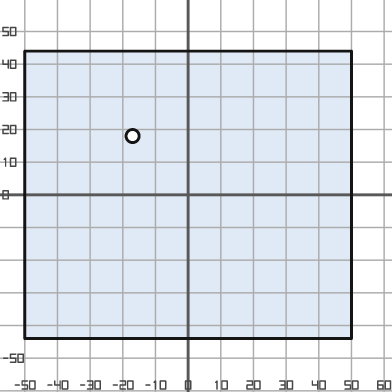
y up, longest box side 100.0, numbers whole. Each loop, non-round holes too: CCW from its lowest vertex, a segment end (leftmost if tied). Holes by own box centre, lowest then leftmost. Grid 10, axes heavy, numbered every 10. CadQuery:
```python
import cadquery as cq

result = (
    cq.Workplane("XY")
    .moveTo(-50.0, -44.0)
    .lineTo(50.0, -44.0)
    .lineTo(50.0, 44.0)
    .lineTo(-50.0, 44.0)
    .close()
    .moveTo(-17.0, 18.0)
    .circle(2.0)
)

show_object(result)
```